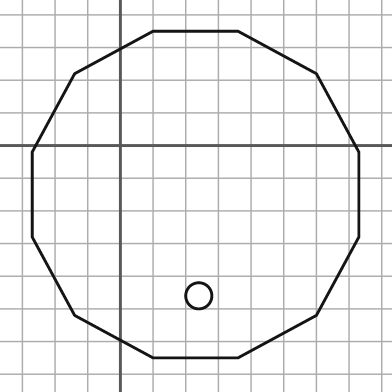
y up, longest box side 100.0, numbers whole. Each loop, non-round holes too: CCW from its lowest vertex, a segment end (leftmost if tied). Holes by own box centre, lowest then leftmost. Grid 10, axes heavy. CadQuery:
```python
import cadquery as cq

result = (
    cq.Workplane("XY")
    .moveTo(10.0, -65.0)
    .lineTo(36.0, -65.0)
    .lineTo(60.0, -52.0)
    .lineTo(73.0, -28.0)
    .lineTo(73.0, -2.0)
    .lineTo(60.0, 22.0)
    .lineTo(36.0, 35.0)
    .lineTo(10.0, 35.0)
    .lineTo(-14.0, 22.0)
    .lineTo(-27.0, -2.0)
    .lineTo(-27.0, -28.0)
    .lineTo(-14.0, -52.0)
    .close()
    .moveTo(24.0, -46.0)
    .circle(4.0)
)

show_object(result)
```